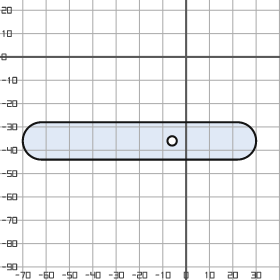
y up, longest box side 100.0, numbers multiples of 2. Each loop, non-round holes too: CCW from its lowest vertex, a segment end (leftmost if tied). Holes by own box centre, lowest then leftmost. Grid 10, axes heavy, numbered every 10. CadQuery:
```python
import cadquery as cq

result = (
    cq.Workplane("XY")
    .moveTo(-62.0, -44.0)
    .lineTo(22.0, -44.0)
    .threePointArc((30.0, -36.0), (22.0, -28.0))
    .lineTo(-62.0, -28.0)
    .threePointArc((-70.0, -36.0), (-62.0, -44.0))
    .close()
    .moveTo(-6.0, -36.0)
    .circle(2.0)
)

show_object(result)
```